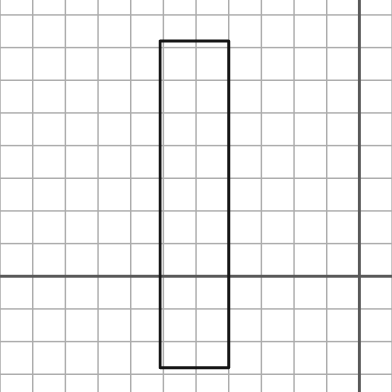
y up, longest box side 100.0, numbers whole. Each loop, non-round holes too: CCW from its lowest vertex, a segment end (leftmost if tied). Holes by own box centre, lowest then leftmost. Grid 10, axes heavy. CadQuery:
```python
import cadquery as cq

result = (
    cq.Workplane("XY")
    .moveTo(-61.0, -28.0)
    .lineTo(-40.0, -28.0)
    .lineTo(-40.0, 72.0)
    .lineTo(-61.0, 72.0)
    .close()
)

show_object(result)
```